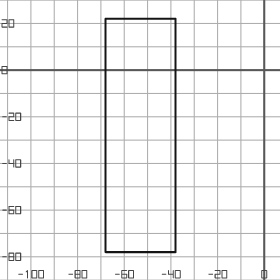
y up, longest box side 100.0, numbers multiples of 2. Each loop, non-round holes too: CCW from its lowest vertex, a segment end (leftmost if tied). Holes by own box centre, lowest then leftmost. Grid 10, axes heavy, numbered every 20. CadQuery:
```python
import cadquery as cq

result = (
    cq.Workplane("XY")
    .moveTo(-68.0, -78.0)
    .lineTo(-38.0, -78.0)
    .lineTo(-38.0, 22.0)
    .lineTo(-68.0, 22.0)
    .close()
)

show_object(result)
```